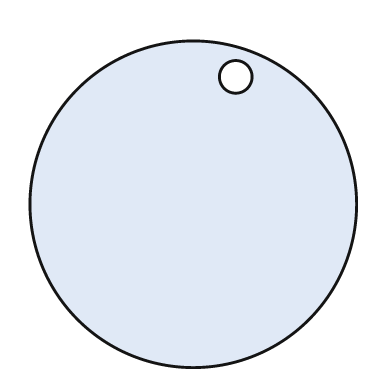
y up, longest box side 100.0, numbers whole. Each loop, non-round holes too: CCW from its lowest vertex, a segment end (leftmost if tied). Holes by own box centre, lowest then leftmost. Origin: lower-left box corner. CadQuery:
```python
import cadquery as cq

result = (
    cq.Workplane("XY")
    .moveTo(50.0, 50.0)
    .circle(50.0)
    .moveTo(63.0, 89.0)
    .circle(5.0)
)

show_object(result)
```